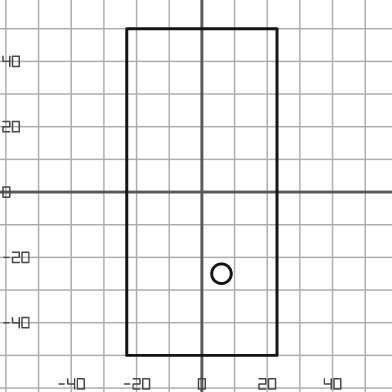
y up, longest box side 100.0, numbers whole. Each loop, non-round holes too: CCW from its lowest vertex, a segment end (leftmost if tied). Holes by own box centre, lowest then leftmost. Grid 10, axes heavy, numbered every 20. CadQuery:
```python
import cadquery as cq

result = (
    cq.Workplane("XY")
    .moveTo(-23.0, -50.0)
    .lineTo(23.0, -50.0)
    .lineTo(23.0, 50.0)
    .lineTo(-23.0, 50.0)
    .close()
    .moveTo(6.0, -25.0)
    .circle(3.0)
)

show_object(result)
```